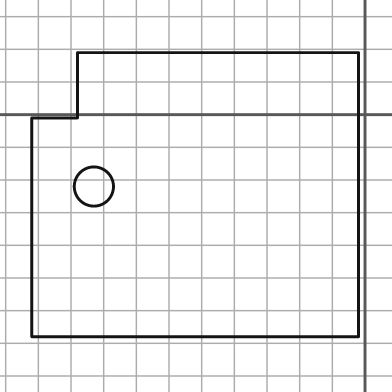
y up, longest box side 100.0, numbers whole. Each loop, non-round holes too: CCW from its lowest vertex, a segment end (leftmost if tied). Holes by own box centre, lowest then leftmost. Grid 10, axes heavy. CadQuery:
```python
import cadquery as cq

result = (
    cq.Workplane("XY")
    .moveTo(-102.0, -68.0)
    .lineTo(-2.0, -68.0)
    .lineTo(-2.0, 19.0)
    .lineTo(-88.0, 19.0)
    .lineTo(-88.0, -1.0)
    .lineTo(-102.0, -1.0)
    .close()
    .moveTo(-83.0, -22.0)
    .circle(6.0)
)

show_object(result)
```